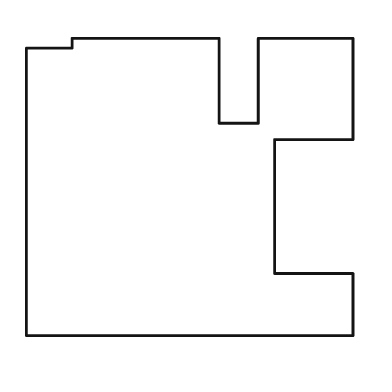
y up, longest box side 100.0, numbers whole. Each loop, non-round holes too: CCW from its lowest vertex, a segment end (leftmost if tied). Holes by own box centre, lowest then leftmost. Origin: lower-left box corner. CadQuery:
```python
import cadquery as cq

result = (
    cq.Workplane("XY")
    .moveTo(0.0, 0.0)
    .lineTo(100.0, 0.0)
    .lineTo(100.0, 19.0)
    .lineTo(76.0, 19.0)
    .lineTo(76.0, 60.0)
    .lineTo(100.0, 60.0)
    .lineTo(100.0, 91.0)
    .lineTo(71.0, 91.0)
    .lineTo(71.0, 65.0)
    .lineTo(59.0, 65.0)
    .lineTo(59.0, 91.0)
    .lineTo(14.0, 91.0)
    .lineTo(14.0, 88.0)
    .lineTo(0.0, 88.0)
    .close()
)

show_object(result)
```